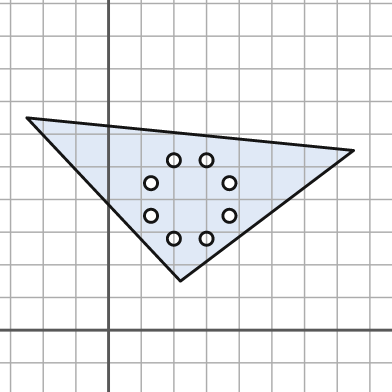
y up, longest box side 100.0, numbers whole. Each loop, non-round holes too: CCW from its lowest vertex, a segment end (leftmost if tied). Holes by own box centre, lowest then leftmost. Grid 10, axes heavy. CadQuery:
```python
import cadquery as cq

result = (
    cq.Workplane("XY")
    .moveTo(22.0, 15.0)
    .lineTo(75.0, 55.0)
    .lineTo(-25.0, 65.0)
    .close()
    .moveTo(20.0, 28.0)
    .circle(2.0)
    .moveTo(30.0, 28.0)
    .circle(2.0)
    .moveTo(13.0, 35.0)
    .circle(2.0)
    .moveTo(37.0, 35.0)
    .circle(2.0)
    .moveTo(13.0, 45.0)
    .circle(2.0)
    .moveTo(37.0, 45.0)
    .circle(2.0)
    .moveTo(20.0, 52.0)
    .circle(2.0)
    .moveTo(30.0, 52.0)
    .circle(2.0)
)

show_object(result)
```